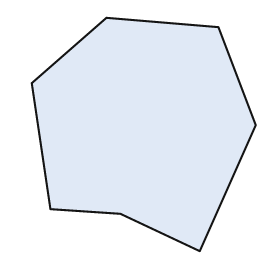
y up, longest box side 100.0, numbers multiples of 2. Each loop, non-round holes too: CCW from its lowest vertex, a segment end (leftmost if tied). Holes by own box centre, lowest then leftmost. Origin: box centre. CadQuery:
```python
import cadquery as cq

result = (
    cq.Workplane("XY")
    .moveTo(24.0, -50.0)
    .lineTo(48.0, 4.0)
    .lineTo(32.0, 46.0)
    .lineTo(-16.0, 50.0)
    .lineTo(-48.0, 22.0)
    .lineTo(-40.0, -32.0)
    .lineTo(-10.0, -34.0)
    .close()
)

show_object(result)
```